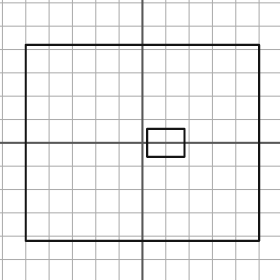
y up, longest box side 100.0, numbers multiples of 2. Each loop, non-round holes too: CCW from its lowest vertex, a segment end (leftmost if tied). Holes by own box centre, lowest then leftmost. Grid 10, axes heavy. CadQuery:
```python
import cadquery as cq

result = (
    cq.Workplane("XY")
    .moveTo(-50.0, -42.0)
    .lineTo(50.0, -42.0)
    .lineTo(50.0, 42.0)
    .lineTo(-50.0, 42.0)
    .close()
    .moveTo(2.0, -6.0)
    .lineTo(18.0, -6.0)
    .lineTo(18.0, 6.0)
    .lineTo(2.0, 6.0)
    .close()
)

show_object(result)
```